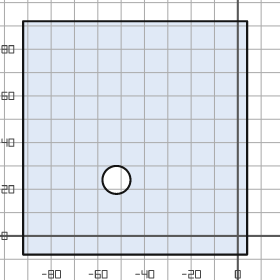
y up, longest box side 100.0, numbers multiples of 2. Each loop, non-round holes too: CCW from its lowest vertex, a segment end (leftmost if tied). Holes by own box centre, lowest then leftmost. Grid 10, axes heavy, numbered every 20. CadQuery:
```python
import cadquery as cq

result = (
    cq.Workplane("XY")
    .moveTo(-92.0, -8.0)
    .lineTo(4.0, -8.0)
    .lineTo(4.0, 92.0)
    .lineTo(-92.0, 92.0)
    .close()
    .moveTo(-52.0, 24.0)
    .circle(6.0)
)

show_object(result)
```